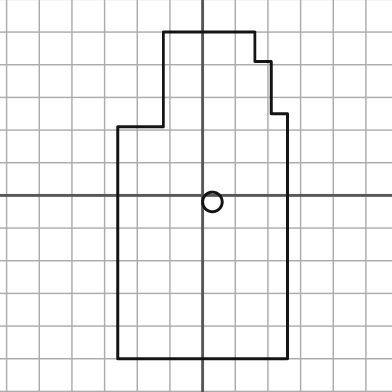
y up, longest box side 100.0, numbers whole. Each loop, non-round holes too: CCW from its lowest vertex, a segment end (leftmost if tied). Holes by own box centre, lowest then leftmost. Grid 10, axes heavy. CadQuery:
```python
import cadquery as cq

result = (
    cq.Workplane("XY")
    .moveTo(-26.0, -50.0)
    .lineTo(26.0, -50.0)
    .lineTo(26.0, 25.0)
    .lineTo(21.0, 25.0)
    .lineTo(21.0, 41.0)
    .lineTo(16.0, 41.0)
    .lineTo(16.0, 50.0)
    .lineTo(-12.0, 50.0)
    .lineTo(-12.0, 21.0)
    .lineTo(-26.0, 21.0)
    .close()
    .moveTo(3.0, -2.0)
    .circle(3.0)
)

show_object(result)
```